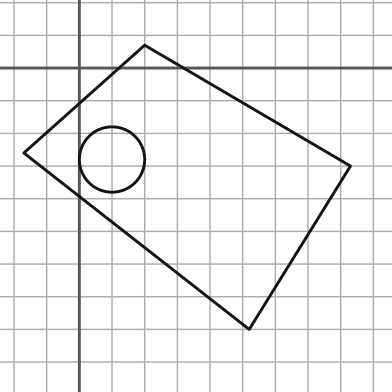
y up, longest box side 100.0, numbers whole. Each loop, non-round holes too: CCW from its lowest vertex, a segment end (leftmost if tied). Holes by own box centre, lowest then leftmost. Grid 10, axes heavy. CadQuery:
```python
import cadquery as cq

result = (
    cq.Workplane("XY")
    .moveTo(52.0, -80.0)
    .lineTo(83.0, -30.0)
    .lineTo(20.0, 7.0)
    .lineTo(-17.0, -26.0)
    .close()
    .moveTo(10.0, -28.0)
    .circle(10.0)
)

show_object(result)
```